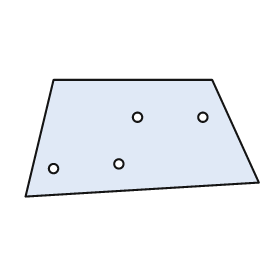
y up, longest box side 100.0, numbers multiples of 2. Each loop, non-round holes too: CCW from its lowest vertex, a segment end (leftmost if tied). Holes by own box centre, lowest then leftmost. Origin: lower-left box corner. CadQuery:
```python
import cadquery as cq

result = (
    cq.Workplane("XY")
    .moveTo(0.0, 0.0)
    .lineTo(100.0, 6.0)
    .lineTo(80.0, 50.0)
    .lineTo(12.0, 50.0)
    .close()
    .moveTo(12.0, 12.0)
    .circle(2.0)
    .moveTo(40.0, 14.0)
    .circle(2.0)
    .moveTo(48.0, 34.0)
    .circle(2.0)
    .moveTo(76.0, 34.0)
    .circle(2.0)
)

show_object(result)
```